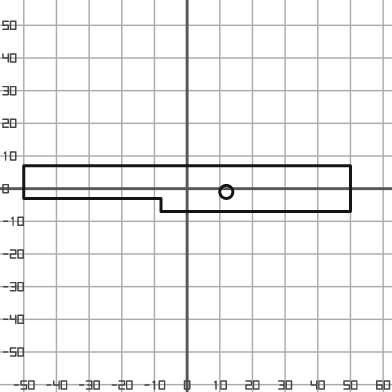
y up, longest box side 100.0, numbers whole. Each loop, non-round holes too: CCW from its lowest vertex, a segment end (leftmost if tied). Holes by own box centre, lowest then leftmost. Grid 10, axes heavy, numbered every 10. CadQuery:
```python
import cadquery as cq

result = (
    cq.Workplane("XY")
    .moveTo(-8.0, -7.0)
    .lineTo(50.0, -7.0)
    .lineTo(50.0, 7.0)
    .lineTo(-50.0, 7.0)
    .lineTo(-50.0, -3.0)
    .lineTo(-8.0, -3.0)
    .close()
    .moveTo(12.0, -1.0)
    .circle(2.0)
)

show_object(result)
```